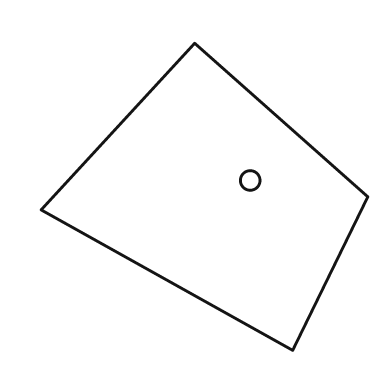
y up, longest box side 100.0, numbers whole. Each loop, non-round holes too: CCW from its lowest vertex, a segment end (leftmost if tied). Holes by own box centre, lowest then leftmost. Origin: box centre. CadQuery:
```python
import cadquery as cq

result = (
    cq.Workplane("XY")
    .moveTo(27.0, -47.0)
    .lineTo(50.0, 0.0)
    .lineTo(-3.0, 47.0)
    .lineTo(-50.0, -4.0)
    .close()
    .moveTo(14.0, 5.0)
    .circle(3.0)
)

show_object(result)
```